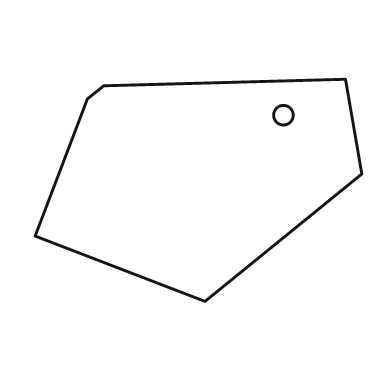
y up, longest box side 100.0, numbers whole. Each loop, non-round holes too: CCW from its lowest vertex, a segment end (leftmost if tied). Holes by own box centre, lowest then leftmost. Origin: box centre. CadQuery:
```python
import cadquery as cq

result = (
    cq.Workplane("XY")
    .moveTo(2.0, -34.0)
    .lineTo(50.0, 5.0)
    .lineTo(45.0, 34.0)
    .lineTo(-29.0, 32.0)
    .lineTo(-34.0, 28.0)
    .lineTo(-50.0, -14.0)
    .close()
    .moveTo(26.0, 23.0)
    .circle(3.0)
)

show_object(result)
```